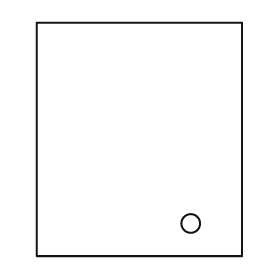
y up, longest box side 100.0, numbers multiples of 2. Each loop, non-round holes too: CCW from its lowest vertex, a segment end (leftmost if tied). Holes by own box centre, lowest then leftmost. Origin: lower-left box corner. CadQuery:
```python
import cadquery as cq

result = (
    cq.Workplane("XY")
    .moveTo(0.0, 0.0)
    .lineTo(88.0, 0.0)
    .lineTo(88.0, 100.0)
    .lineTo(0.0, 100.0)
    .close()
    .moveTo(66.0, 14.0)
    .circle(4.0)
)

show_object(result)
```